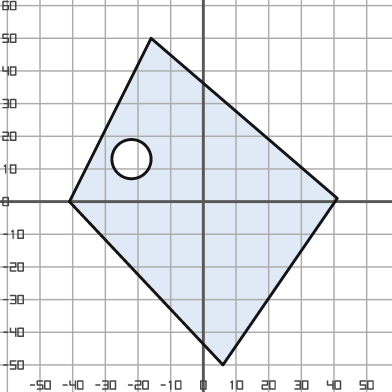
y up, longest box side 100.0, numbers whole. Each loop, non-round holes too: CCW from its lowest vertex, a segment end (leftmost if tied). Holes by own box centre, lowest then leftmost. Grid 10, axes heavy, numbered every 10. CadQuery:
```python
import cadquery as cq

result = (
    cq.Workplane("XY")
    .moveTo(6.0, -50.0)
    .lineTo(41.0, 1.0)
    .lineTo(-16.0, 50.0)
    .lineTo(-41.0, 0.0)
    .close()
    .moveTo(-22.0, 13.0)
    .circle(6.0)
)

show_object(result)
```